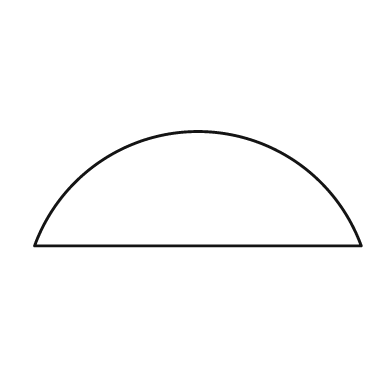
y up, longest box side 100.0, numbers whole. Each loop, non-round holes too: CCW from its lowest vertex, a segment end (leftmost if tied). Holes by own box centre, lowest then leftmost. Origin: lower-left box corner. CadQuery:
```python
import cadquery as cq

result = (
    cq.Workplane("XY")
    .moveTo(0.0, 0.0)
    .lineTo(100.0, 0.0)
    .threePointArc((50.0, 35.0), (0.0, 0.0))
    .close()
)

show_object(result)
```